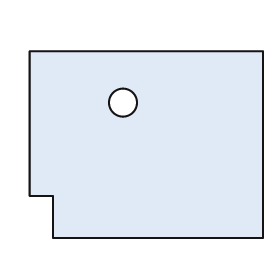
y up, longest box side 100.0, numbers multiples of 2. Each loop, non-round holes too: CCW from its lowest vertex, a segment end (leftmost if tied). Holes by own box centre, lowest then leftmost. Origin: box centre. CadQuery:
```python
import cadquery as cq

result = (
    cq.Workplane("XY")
    .moveTo(-40.0, -40.0)
    .lineTo(50.0, -40.0)
    .lineTo(50.0, 40.0)
    .lineTo(-50.0, 40.0)
    .lineTo(-50.0, -22.0)
    .lineTo(-40.0, -22.0)
    .close()
    .moveTo(-10.0, 18.0)
    .circle(6.0)
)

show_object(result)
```